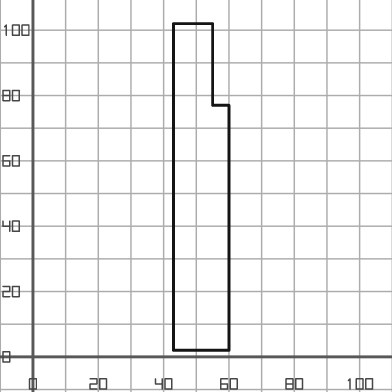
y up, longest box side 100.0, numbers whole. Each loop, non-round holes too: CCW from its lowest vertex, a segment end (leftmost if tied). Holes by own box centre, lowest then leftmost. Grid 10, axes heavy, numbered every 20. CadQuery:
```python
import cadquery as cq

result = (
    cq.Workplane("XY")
    .moveTo(43.0, 2.0)
    .lineTo(60.0, 2.0)
    .lineTo(60.0, 77.0)
    .lineTo(55.0, 77.0)
    .lineTo(55.0, 102.0)
    .lineTo(43.0, 102.0)
    .close()
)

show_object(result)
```